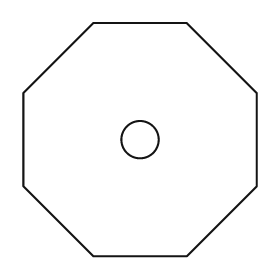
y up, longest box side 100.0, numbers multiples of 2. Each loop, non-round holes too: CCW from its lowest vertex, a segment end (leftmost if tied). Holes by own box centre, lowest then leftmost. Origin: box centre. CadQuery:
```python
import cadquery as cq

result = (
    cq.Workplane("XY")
    .moveTo(-20.0, -50.0)
    .lineTo(20.0, -50.0)
    .lineTo(50.0, -20.0)
    .lineTo(50.0, 20.0)
    .lineTo(20.0, 50.0)
    .lineTo(-20.0, 50.0)
    .lineTo(-50.0, 20.0)
    .lineTo(-50.0, -20.0)
    .close()
    .moveTo(0.0, 0.0)
    .circle(8.0)
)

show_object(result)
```